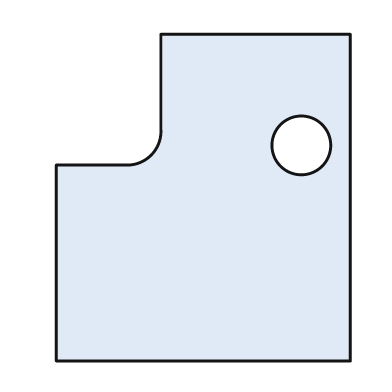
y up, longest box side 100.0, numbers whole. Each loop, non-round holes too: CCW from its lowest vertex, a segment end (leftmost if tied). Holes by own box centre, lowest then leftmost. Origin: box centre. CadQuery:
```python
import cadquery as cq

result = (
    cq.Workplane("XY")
    .moveTo(-45.0, -50.0)
    .lineTo(45.0, -50.0)
    .lineTo(45.0, 50.0)
    .lineTo(-13.0, 50.0)
    .lineTo(-13.0, 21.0)
    .threePointArc((-16.0, 13.0), (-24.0, 10.0))
    .lineTo(-45.0, 10.0)
    .close()
    .moveTo(30.0, 16.0)
    .circle(9.0)
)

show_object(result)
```